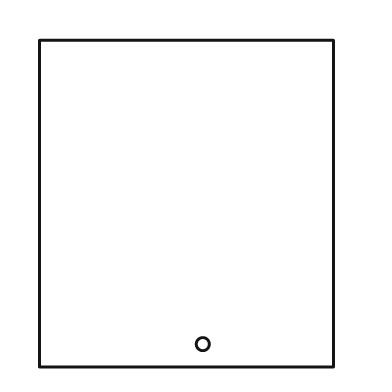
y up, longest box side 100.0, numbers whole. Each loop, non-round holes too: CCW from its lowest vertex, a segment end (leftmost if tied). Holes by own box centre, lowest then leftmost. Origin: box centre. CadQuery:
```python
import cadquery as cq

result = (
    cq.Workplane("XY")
    .moveTo(-45.0, -50.0)
    .lineTo(45.0, -50.0)
    .lineTo(45.0, 50.0)
    .lineTo(-45.0, 50.0)
    .close()
    .moveTo(5.0, -43.0)
    .circle(2.0)
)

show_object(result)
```